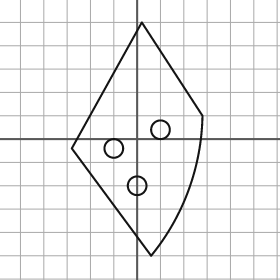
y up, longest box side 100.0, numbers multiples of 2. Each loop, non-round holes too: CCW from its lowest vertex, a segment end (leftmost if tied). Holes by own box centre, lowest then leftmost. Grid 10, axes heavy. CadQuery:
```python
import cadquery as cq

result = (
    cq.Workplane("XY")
    .moveTo(6.0, -50.0)
    .threePointArc((22.0, -22.0), (28.0, 10.0))
    .lineTo(2.0, 50.0)
    .lineTo(-28.0, -4.0)
    .close()
    .moveTo(0.0, -20.0)
    .circle(4.0)
    .moveTo(-10.0, -4.0)
    .circle(4.0)
    .moveTo(10.0, 4.0)
    .circle(4.0)
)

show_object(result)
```